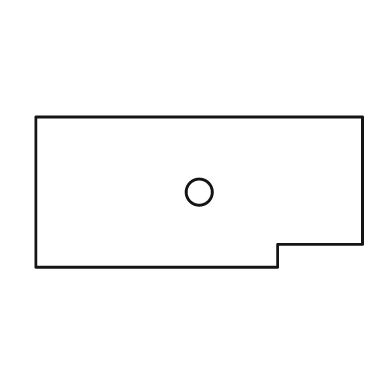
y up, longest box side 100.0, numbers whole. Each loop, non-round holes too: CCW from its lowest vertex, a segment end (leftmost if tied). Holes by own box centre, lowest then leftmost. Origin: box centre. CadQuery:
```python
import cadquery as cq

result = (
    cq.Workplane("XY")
    .moveTo(-50.0, -23.0)
    .lineTo(24.0, -23.0)
    .lineTo(24.0, -16.0)
    .lineTo(50.0, -16.0)
    .lineTo(50.0, 23.0)
    .lineTo(-50.0, 23.0)
    .close()
    .moveTo(0.0, 0.0)
    .circle(4.0)
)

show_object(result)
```